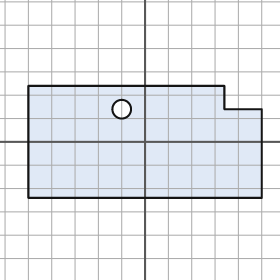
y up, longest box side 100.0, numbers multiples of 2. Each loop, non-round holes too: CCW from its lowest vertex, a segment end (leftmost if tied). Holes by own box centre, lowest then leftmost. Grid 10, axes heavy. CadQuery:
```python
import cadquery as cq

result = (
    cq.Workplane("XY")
    .moveTo(-50.0, -24.0)
    .lineTo(50.0, -24.0)
    .lineTo(50.0, 14.0)
    .lineTo(34.0, 14.0)
    .lineTo(34.0, 24.0)
    .lineTo(-50.0, 24.0)
    .close()
    .moveTo(-10.0, 14.0)
    .circle(4.0)
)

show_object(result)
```